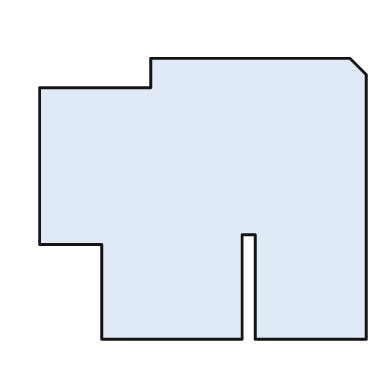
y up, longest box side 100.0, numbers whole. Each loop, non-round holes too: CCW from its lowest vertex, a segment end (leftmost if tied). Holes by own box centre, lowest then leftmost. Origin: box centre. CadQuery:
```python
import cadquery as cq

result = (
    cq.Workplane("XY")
    .moveTo(-31.0, -43.0)
    .lineTo(12.0, -43.0)
    .lineTo(12.0, -11.0)
    .lineTo(16.0, -11.0)
    .lineTo(16.0, -43.0)
    .lineTo(50.0, -43.0)
    .lineTo(50.0, 38.0)
    .lineTo(45.0, 43.0)
    .lineTo(-16.0, 43.0)
    .lineTo(-16.0, 34.0)
    .lineTo(-50.0, 34.0)
    .lineTo(-50.0, -14.0)
    .lineTo(-31.0, -14.0)
    .close()
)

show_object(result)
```